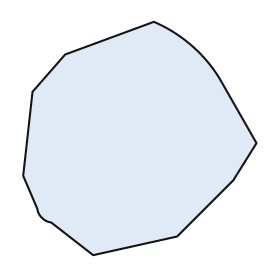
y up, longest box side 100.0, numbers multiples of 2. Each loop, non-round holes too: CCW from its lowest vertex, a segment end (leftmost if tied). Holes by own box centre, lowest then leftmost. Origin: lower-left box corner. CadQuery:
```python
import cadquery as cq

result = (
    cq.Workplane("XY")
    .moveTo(30.0, 0.0)
    .lineTo(66.0, 8.0)
    .lineTo(90.0, 32.0)
    .lineTo(100.0, 48.0)
    .lineTo(84.0, 76.0)
    .threePointArc((72.0, 90.0), (56.0, 100.0))
    .lineTo(18.0, 86.0)
    .lineTo(4.0, 70.0)
    .lineTo(0.0, 34.0)
    .lineTo(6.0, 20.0)
    .threePointArc((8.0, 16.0), (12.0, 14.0))
    .close()
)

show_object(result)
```